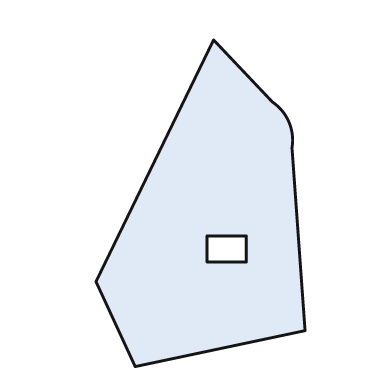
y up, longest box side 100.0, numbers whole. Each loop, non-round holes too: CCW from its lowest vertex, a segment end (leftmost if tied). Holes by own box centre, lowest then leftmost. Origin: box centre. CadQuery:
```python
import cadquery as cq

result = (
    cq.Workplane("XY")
    .moveTo(-20.0, -50.0)
    .lineTo(32.0, -39.0)
    .lineTo(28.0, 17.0)
    .threePointArc((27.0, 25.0), (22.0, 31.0))
    .lineTo(4.0, 50.0)
    .lineTo(-32.0, -24.0)
    .close()
    .moveTo(2.0, -18.0)
    .lineTo(14.0, -18.0)
    .lineTo(14.0, -10.0)
    .lineTo(2.0, -10.0)
    .close()
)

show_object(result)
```